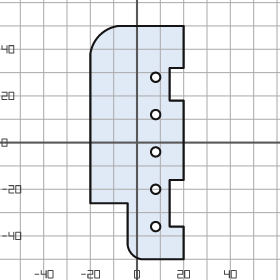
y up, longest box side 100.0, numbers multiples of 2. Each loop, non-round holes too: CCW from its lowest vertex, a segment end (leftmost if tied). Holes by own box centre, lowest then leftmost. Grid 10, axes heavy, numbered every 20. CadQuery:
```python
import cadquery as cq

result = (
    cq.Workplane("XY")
    .moveTo(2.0, -50.0)
    .lineTo(20.0, -50.0)
    .lineTo(20.0, -36.0)
    .lineTo(14.0, -36.0)
    .lineTo(14.0, -16.0)
    .lineTo(20.0, -16.0)
    .lineTo(20.0, 18.0)
    .lineTo(14.0, 18.0)
    .lineTo(14.0, 32.0)
    .lineTo(20.0, 32.0)
    .lineTo(20.0, 50.0)
    .lineTo(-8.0, 50.0)
    .threePointArc((-16.0, 46.0), (-20.0, 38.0))
    .lineTo(-20.0, -26.0)
    .lineTo(-4.0, -26.0)
    .lineTo(-4.0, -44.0)
    .threePointArc((-2.0, -48.0), (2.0, -50.0))
    .close()
    .moveTo(8.0, -36.0)
    .circle(2.0)
    .moveTo(8.0, -20.0)
    .circle(2.0)
    .moveTo(8.0, -4.0)
    .circle(2.0)
    .moveTo(8.0, 12.0)
    .circle(2.0)
    .moveTo(8.0, 28.0)
    .circle(2.0)
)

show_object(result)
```